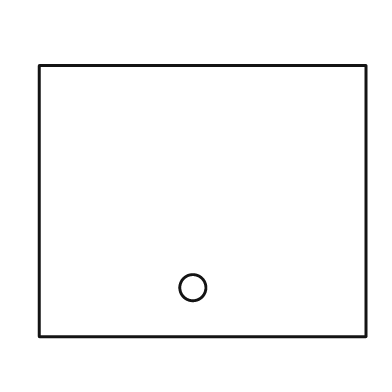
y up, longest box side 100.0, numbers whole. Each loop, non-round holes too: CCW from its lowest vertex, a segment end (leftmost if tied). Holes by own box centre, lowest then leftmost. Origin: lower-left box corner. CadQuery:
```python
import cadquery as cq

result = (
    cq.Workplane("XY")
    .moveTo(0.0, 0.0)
    .lineTo(100.0, 0.0)
    .lineTo(100.0, 83.0)
    .lineTo(0.0, 83.0)
    .close()
    .moveTo(47.0, 15.0)
    .circle(4.0)
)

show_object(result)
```